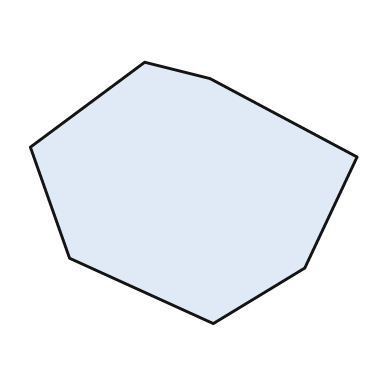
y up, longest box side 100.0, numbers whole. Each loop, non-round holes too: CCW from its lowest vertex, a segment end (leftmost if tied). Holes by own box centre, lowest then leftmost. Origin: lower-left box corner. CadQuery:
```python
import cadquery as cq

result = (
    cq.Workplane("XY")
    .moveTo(56.0, 0.0)
    .lineTo(84.0, 17.0)
    .lineTo(100.0, 51.0)
    .lineTo(55.0, 75.0)
    .lineTo(35.0, 80.0)
    .lineTo(0.0, 54.0)
    .lineTo(12.0, 20.0)
    .close()
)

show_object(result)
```